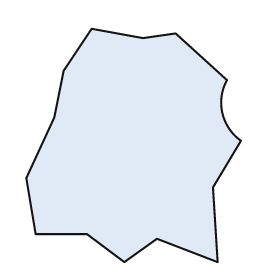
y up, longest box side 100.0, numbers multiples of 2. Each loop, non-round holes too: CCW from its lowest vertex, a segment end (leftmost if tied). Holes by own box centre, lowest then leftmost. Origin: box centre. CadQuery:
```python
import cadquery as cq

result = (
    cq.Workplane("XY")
    .moveTo(-4.0, -50.0)
    .lineTo(10.0, -40.0)
    .lineTo(36.0, -50.0)
    .lineTo(34.0, -18.0)
    .lineTo(46.0, 2.0)
    .threePointArc((38.0, 14.0), (40.0, 28.0))
    .lineTo(18.0, 48.0)
    .lineTo(4.0, 46.0)
    .lineTo(-18.0, 50.0)
    .lineTo(-30.0, 32.0)
    .lineTo(-34.0, 12.0)
    .lineTo(-46.0, -14.0)
    .lineTo(-42.0, -38.0)
    .lineTo(-20.0, -38.0)
    .close()
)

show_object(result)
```